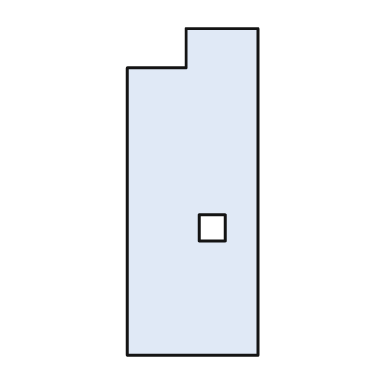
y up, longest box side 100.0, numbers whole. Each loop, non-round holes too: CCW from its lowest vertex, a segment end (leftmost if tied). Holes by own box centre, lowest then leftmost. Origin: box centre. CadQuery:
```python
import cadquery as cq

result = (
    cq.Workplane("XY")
    .moveTo(-20.0, -50.0)
    .lineTo(20.0, -50.0)
    .lineTo(20.0, 50.0)
    .lineTo(-2.0, 50.0)
    .lineTo(-2.0, 38.0)
    .lineTo(-20.0, 38.0)
    .close()
    .moveTo(2.0, -15.0)
    .lineTo(10.0, -15.0)
    .lineTo(10.0, -7.0)
    .lineTo(2.0, -7.0)
    .close()
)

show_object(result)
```